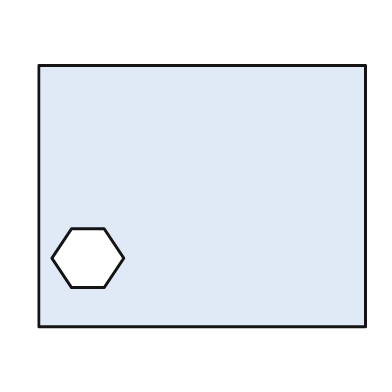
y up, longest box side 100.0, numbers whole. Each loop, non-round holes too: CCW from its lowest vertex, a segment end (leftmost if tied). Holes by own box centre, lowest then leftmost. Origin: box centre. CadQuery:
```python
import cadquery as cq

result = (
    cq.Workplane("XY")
    .moveTo(-50.0, -40.0)
    .lineTo(50.0, -40.0)
    .lineTo(50.0, 40.0)
    .lineTo(-50.0, 40.0)
    .close()
    .moveTo(-40.0, -28.0)
    .lineTo(-30.0, -28.0)
    .lineTo(-24.0, -19.0)
    .lineTo(-30.0, -10.0)
    .lineTo(-40.0, -10.0)
    .lineTo(-46.0, -19.0)
    .close()
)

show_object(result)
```